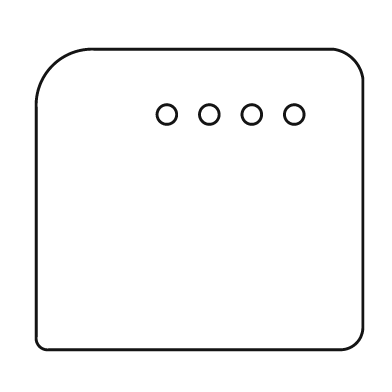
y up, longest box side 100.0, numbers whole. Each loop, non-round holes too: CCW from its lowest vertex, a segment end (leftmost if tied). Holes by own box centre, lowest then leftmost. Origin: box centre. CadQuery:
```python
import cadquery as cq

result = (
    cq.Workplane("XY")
    .moveTo(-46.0, -46.0)
    .lineTo(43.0, -46.0)
    .threePointArc((48.0, -44.0), (50.0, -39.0))
    .lineTo(50.0, 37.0)
    .threePointArc((47.0, 43.0), (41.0, 46.0))
    .lineTo(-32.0, 46.0)
    .threePointArc((-45.0, 41.0), (-50.0, 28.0))
    .lineTo(-50.0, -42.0)
    .threePointArc((-49.0, -45.0), (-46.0, -46.0))
    .close()
    .moveTo(-10.0, 26.0)
    .circle(3.0)
    .moveTo(3.0, 26.0)
    .circle(3.0)
    .moveTo(16.0, 26.0)
    .circle(3.0)
    .moveTo(29.0, 26.0)
    .circle(3.0)
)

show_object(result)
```